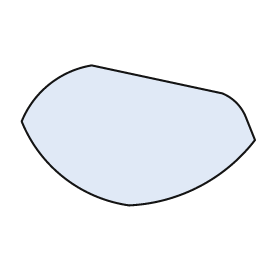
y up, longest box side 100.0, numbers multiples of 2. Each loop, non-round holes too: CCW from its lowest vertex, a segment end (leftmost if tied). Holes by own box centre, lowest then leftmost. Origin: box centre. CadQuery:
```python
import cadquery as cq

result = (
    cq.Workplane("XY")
    .moveTo(-4.0, -30.0)
    .threePointArc((26.0, -22.0), (50.0, -2.0))
    .lineTo(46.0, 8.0)
    .threePointArc((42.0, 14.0), (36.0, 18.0))
    .lineTo(-20.0, 30.0)
    .threePointArc((-38.0, 22.0), (-50.0, 6.0))
    .threePointArc((-32.0, -18.0), (-4.0, -30.0))
    .close()
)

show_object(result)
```